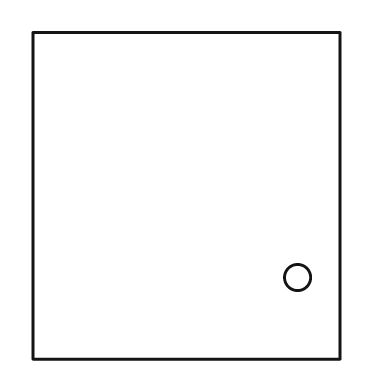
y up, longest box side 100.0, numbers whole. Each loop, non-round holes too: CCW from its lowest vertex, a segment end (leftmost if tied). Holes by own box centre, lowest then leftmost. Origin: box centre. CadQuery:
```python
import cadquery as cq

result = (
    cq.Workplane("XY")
    .moveTo(-47.0, -50.0)
    .lineTo(47.0, -50.0)
    .lineTo(47.0, 50.0)
    .lineTo(-47.0, 50.0)
    .close()
    .moveTo(34.0, -25.0)
    .circle(4.0)
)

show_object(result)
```